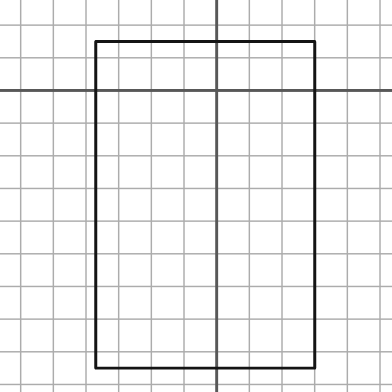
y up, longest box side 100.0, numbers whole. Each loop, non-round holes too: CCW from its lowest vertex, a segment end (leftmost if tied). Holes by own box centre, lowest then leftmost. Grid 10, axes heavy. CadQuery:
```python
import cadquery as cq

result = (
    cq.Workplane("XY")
    .moveTo(-37.0, -85.0)
    .lineTo(30.0, -85.0)
    .lineTo(30.0, 15.0)
    .lineTo(-37.0, 15.0)
    .close()
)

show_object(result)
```